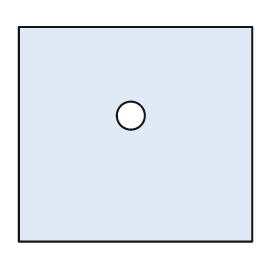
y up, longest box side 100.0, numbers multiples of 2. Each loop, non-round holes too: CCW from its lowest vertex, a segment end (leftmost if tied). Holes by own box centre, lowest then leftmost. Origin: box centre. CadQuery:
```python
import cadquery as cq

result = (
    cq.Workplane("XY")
    .moveTo(-50.0, -46.0)
    .lineTo(50.0, -46.0)
    .lineTo(50.0, 46.0)
    .lineTo(-50.0, 46.0)
    .close()
    .moveTo(-2.0, 8.0)
    .circle(6.0)
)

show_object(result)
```